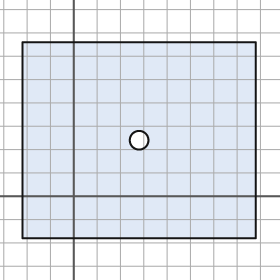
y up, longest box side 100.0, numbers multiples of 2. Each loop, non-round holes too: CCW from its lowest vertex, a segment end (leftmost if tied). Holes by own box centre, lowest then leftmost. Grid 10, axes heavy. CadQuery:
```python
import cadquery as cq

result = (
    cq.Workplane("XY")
    .moveTo(-22.0, -18.0)
    .lineTo(78.0, -18.0)
    .lineTo(78.0, 66.0)
    .lineTo(-22.0, 66.0)
    .close()
    .moveTo(28.0, 24.0)
    .circle(4.0)
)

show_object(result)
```